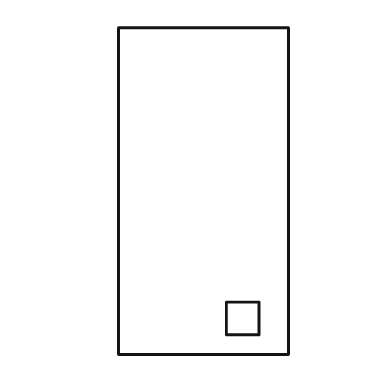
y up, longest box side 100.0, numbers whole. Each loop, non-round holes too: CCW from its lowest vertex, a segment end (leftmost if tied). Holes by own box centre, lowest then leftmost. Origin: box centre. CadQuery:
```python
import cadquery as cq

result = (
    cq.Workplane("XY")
    .moveTo(-26.0, -50.0)
    .lineTo(26.0, -50.0)
    .lineTo(26.0, 50.0)
    .lineTo(-26.0, 50.0)
    .close()
    .moveTo(7.0, -44.0)
    .lineTo(17.0, -44.0)
    .lineTo(17.0, -34.0)
    .lineTo(7.0, -34.0)
    .close()
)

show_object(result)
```